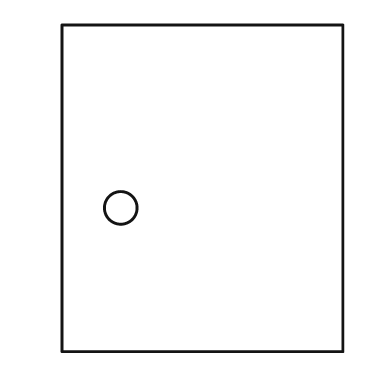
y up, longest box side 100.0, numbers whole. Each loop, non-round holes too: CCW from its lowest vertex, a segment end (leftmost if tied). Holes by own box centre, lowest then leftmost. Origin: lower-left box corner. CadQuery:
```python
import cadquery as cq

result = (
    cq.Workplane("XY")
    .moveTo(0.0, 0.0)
    .lineTo(86.0, 0.0)
    .lineTo(86.0, 100.0)
    .lineTo(0.0, 100.0)
    .close()
    .moveTo(18.0, 44.0)
    .circle(5.0)
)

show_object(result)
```